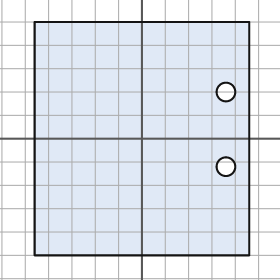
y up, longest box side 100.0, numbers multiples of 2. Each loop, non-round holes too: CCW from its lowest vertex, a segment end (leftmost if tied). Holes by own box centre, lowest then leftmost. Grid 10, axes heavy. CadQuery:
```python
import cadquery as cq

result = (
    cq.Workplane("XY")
    .moveTo(-46.0, -50.0)
    .lineTo(46.0, -50.0)
    .lineTo(46.0, 50.0)
    .lineTo(-46.0, 50.0)
    .close()
    .moveTo(36.0, -12.0)
    .circle(4.0)
    .moveTo(36.0, 20.0)
    .circle(4.0)
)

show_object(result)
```